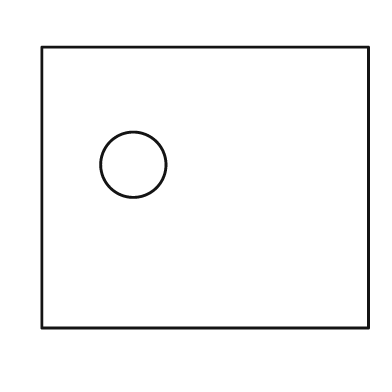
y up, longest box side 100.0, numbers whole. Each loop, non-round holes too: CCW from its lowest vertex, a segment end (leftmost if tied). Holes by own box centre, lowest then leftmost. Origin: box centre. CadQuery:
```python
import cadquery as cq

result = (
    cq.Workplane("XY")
    .moveTo(-50.0, -43.0)
    .lineTo(50.0, -43.0)
    .lineTo(50.0, 43.0)
    .lineTo(-50.0, 43.0)
    .close()
    .moveTo(-22.0, 7.0)
    .circle(10.0)
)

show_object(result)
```